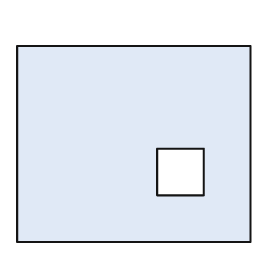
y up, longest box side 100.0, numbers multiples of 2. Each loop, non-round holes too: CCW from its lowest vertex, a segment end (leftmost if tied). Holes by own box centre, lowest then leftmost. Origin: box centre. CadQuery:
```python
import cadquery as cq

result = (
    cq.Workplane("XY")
    .moveTo(-50.0, -42.0)
    .lineTo(50.0, -42.0)
    .lineTo(50.0, 42.0)
    .lineTo(-50.0, 42.0)
    .close()
    .moveTo(10.0, -22.0)
    .lineTo(30.0, -22.0)
    .lineTo(30.0, -2.0)
    .lineTo(10.0, -2.0)
    .close()
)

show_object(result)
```